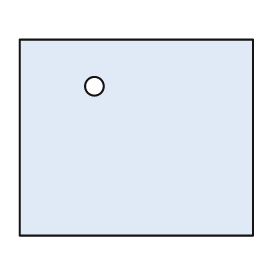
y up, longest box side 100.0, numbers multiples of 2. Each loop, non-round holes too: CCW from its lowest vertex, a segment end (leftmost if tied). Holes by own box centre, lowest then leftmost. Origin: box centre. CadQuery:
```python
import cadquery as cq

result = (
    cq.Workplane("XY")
    .moveTo(-50.0, -42.0)
    .lineTo(50.0, -42.0)
    .lineTo(50.0, 42.0)
    .lineTo(-50.0, 42.0)
    .close()
    .moveTo(-18.0, 22.0)
    .circle(4.0)
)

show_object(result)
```